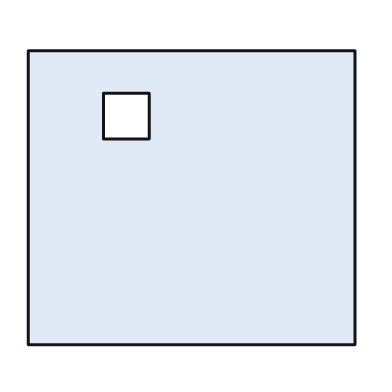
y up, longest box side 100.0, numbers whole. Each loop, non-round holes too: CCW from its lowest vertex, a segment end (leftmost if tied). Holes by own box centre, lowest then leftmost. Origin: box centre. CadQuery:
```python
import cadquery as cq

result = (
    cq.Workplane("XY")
    .moveTo(-50.0, -45.0)
    .lineTo(50.0, -45.0)
    .lineTo(50.0, 45.0)
    .lineTo(-50.0, 45.0)
    .close()
    .moveTo(-27.0, 18.0)
    .lineTo(-13.0, 18.0)
    .lineTo(-13.0, 32.0)
    .lineTo(-27.0, 32.0)
    .close()
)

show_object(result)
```